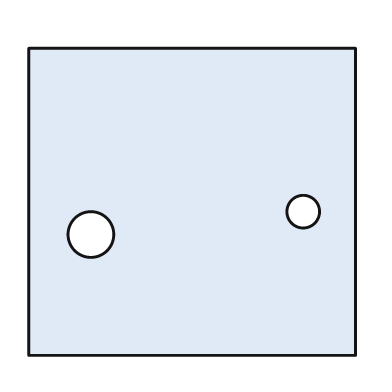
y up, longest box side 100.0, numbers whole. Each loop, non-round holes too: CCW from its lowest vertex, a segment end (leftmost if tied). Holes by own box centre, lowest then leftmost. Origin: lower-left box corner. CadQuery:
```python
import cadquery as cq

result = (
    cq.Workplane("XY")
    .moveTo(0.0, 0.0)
    .lineTo(100.0, 0.0)
    .lineTo(100.0, 94.0)
    .lineTo(0.0, 94.0)
    .close()
    .moveTo(19.0, 37.0)
    .circle(7.0)
    .moveTo(84.0, 44.0)
    .circle(5.0)
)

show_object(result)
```